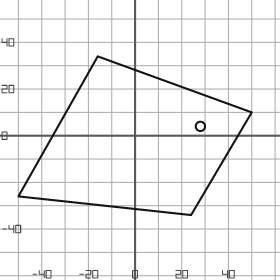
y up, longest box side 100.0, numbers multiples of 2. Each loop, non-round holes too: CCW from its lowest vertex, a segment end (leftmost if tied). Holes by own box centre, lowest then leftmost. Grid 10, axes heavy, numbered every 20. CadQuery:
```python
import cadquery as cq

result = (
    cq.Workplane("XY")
    .moveTo(24.0, -34.0)
    .lineTo(50.0, 10.0)
    .lineTo(-16.0, 34.0)
    .lineTo(-50.0, -26.0)
    .close()
    .moveTo(28.0, 4.0)
    .circle(2.0)
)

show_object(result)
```